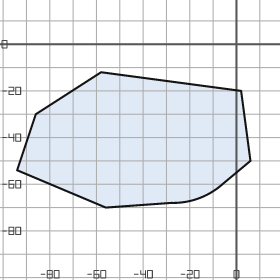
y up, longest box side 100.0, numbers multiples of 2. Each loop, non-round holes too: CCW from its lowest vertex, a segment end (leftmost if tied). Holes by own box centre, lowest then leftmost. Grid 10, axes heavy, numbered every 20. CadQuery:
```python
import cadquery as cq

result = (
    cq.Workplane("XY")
    .moveTo(-56.0, -70.0)
    .lineTo(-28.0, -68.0)
    .threePointArc((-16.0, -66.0), (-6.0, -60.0))
    .lineTo(6.0, -50.0)
    .lineTo(2.0, -20.0)
    .lineTo(-58.0, -12.0)
    .lineTo(-86.0, -30.0)
    .lineTo(-94.0, -54.0)
    .close()
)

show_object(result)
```